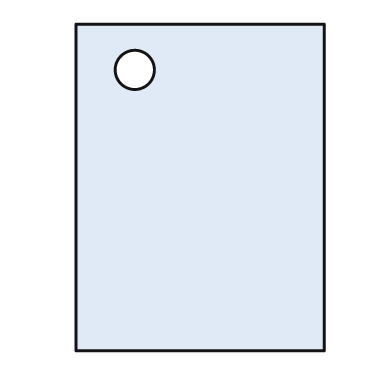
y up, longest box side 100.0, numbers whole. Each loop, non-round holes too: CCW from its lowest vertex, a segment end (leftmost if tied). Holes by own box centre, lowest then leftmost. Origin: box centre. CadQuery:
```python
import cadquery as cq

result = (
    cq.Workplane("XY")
    .moveTo(-38.0, -50.0)
    .lineTo(38.0, -50.0)
    .lineTo(38.0, 50.0)
    .lineTo(-38.0, 50.0)
    .close()
    .moveTo(-20.0, 36.0)
    .circle(6.0)
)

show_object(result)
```